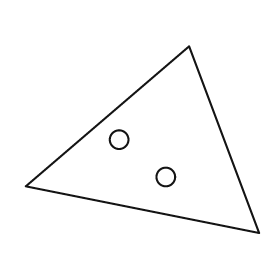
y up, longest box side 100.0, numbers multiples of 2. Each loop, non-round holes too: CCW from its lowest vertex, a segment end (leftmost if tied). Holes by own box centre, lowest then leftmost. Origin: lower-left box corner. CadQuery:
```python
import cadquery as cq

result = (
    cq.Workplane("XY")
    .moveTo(100.0, 0.0)
    .lineTo(70.0, 80.0)
    .lineTo(0.0, 20.0)
    .close()
    .moveTo(60.0, 24.0)
    .circle(4.0)
    .moveTo(40.0, 40.0)
    .circle(4.0)
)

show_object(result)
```